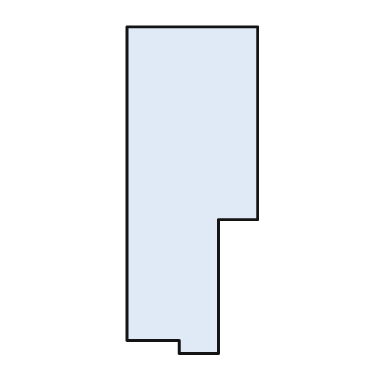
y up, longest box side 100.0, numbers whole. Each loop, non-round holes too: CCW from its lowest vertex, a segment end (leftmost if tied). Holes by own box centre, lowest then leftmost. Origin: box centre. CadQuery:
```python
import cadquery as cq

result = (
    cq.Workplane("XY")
    .moveTo(-4.0, -50.0)
    .lineTo(8.0, -50.0)
    .lineTo(8.0, -9.0)
    .lineTo(20.0, -9.0)
    .lineTo(20.0, 50.0)
    .lineTo(-20.0, 50.0)
    .lineTo(-20.0, -46.0)
    .lineTo(-4.0, -46.0)
    .close()
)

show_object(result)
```